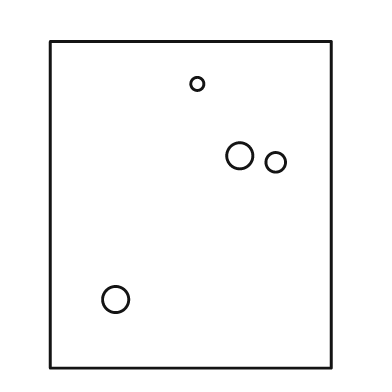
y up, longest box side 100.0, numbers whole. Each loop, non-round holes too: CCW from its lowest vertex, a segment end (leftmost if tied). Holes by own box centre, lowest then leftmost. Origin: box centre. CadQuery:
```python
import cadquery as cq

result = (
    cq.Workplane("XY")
    .moveTo(-43.0, -50.0)
    .lineTo(43.0, -50.0)
    .lineTo(43.0, 50.0)
    .lineTo(-43.0, 50.0)
    .close()
    .moveTo(-23.0, -29.0)
    .circle(4.0)
    .moveTo(26.0, 13.0)
    .circle(3.0)
    .moveTo(15.0, 15.0)
    .circle(4.0)
    .moveTo(2.0, 37.0)
    .circle(2.0)
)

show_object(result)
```